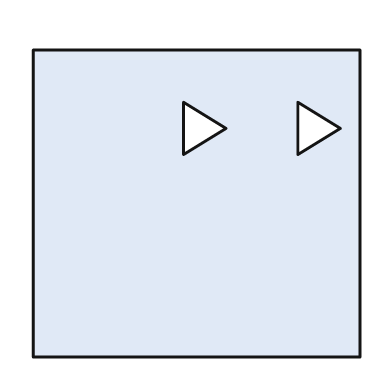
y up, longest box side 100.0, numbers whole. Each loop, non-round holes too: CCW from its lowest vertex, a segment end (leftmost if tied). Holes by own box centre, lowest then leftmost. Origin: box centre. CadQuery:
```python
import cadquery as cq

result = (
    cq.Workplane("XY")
    .moveTo(-50.0, -47.0)
    .lineTo(50.0, -47.0)
    .lineTo(50.0, 47.0)
    .lineTo(-50.0, 47.0)
    .close()
    .moveTo(-4.0, 15.0)
    .lineTo(9.0, 23.0)
    .lineTo(-4.0, 31.0)
    .close()
    .moveTo(31.0, 15.0)
    .lineTo(44.0, 23.0)
    .lineTo(31.0, 31.0)
    .close()
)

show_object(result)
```